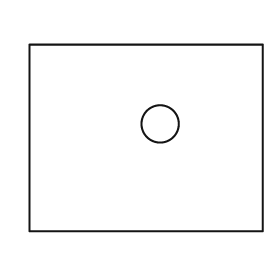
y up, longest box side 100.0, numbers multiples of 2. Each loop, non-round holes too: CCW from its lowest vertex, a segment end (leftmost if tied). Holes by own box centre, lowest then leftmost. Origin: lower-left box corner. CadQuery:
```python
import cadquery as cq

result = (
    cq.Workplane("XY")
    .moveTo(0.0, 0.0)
    .lineTo(100.0, 0.0)
    .lineTo(100.0, 80.0)
    .lineTo(0.0, 80.0)
    .close()
    .moveTo(56.0, 46.0)
    .circle(8.0)
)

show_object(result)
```